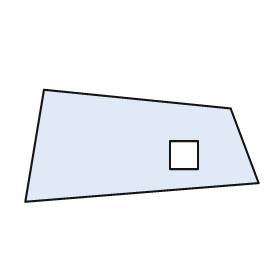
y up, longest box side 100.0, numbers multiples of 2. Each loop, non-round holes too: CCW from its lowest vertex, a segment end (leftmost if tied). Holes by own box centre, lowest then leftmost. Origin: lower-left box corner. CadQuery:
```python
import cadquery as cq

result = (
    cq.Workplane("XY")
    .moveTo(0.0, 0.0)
    .lineTo(100.0, 8.0)
    .lineTo(88.0, 40.0)
    .lineTo(8.0, 48.0)
    .close()
    .moveTo(62.0, 14.0)
    .lineTo(74.0, 14.0)
    .lineTo(74.0, 26.0)
    .lineTo(62.0, 26.0)
    .close()
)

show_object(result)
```